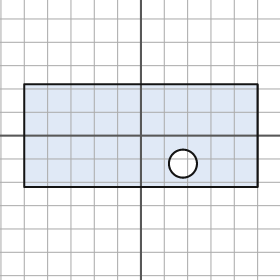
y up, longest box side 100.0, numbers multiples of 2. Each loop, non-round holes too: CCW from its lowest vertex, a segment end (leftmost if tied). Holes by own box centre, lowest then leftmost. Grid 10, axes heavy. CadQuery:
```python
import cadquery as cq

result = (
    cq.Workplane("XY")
    .moveTo(-50.0, -22.0)
    .lineTo(50.0, -22.0)
    .lineTo(50.0, 22.0)
    .lineTo(-50.0, 22.0)
    .close()
    .moveTo(18.0, -12.0)
    .circle(6.0)
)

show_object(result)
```